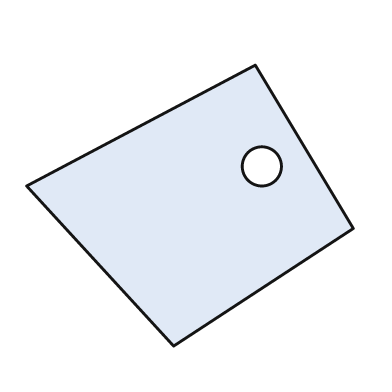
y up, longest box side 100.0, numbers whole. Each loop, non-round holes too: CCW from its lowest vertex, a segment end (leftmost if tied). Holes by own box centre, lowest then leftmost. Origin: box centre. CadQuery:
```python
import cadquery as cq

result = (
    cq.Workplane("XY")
    .moveTo(-5.0, -43.0)
    .lineTo(50.0, -7.0)
    .lineTo(20.0, 43.0)
    .lineTo(-50.0, 6.0)
    .close()
    .moveTo(22.0, 12.0)
    .circle(6.0)
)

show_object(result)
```